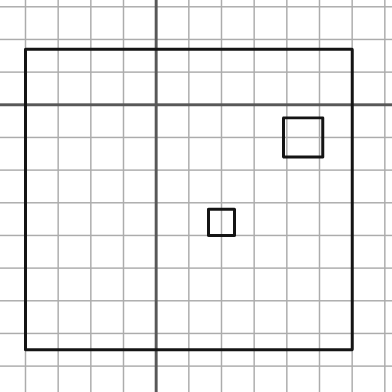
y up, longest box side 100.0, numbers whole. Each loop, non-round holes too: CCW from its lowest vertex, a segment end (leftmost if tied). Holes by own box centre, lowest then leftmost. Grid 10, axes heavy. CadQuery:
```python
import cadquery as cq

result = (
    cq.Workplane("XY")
    .moveTo(-40.0, -75.0)
    .lineTo(60.0, -75.0)
    .lineTo(60.0, 17.0)
    .lineTo(-40.0, 17.0)
    .close()
    .moveTo(16.0, -40.0)
    .lineTo(24.0, -40.0)
    .lineTo(24.0, -32.0)
    .lineTo(16.0, -32.0)
    .close()
    .moveTo(39.0, -16.0)
    .lineTo(51.0, -16.0)
    .lineTo(51.0, -4.0)
    .lineTo(39.0, -4.0)
    .close()
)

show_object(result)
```